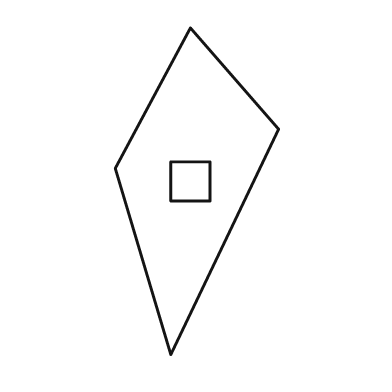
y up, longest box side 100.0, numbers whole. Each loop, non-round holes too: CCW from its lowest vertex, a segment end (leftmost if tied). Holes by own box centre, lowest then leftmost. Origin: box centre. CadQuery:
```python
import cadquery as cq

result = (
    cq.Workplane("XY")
    .moveTo(-8.0, -50.0)
    .lineTo(25.0, 19.0)
    .lineTo(-2.0, 50.0)
    .lineTo(-25.0, 7.0)
    .close()
    .moveTo(-8.0, -3.0)
    .lineTo(4.0, -3.0)
    .lineTo(4.0, 9.0)
    .lineTo(-8.0, 9.0)
    .close()
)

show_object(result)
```